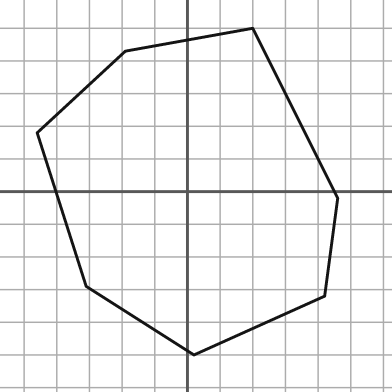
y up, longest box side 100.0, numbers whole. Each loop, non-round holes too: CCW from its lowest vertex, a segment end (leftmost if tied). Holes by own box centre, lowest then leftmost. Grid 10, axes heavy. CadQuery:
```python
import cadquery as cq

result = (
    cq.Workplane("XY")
    .moveTo(2.0, -50.0)
    .lineTo(42.0, -32.0)
    .lineTo(46.0, -2.0)
    .lineTo(20.0, 50.0)
    .lineTo(-19.0, 43.0)
    .lineTo(-46.0, 18.0)
    .lineTo(-31.0, -29.0)
    .close()
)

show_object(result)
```